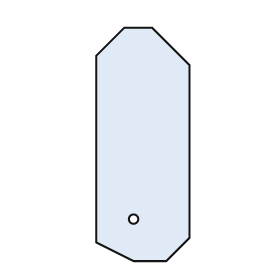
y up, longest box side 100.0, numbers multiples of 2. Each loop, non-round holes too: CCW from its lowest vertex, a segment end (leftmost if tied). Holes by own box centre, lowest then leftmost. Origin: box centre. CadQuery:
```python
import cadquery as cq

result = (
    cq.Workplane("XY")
    .moveTo(-4.0, -50.0)
    .lineTo(10.0, -50.0)
    .lineTo(20.0, -40.0)
    .lineTo(20.0, 34.0)
    .lineTo(4.0, 50.0)
    .lineTo(-8.0, 50.0)
    .lineTo(-20.0, 38.0)
    .lineTo(-20.0, -42.0)
    .close()
    .moveTo(-4.0, -32.0)
    .circle(2.0)
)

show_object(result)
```